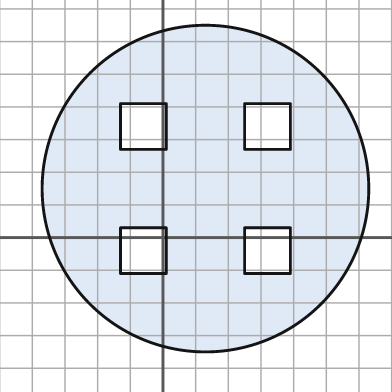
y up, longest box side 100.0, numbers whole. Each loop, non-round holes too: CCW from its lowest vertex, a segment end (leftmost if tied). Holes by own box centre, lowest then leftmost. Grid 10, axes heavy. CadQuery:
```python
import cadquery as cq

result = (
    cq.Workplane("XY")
    .moveTo(13.0, 15.0)
    .circle(50.0)
    .moveTo(-13.0, -11.0)
    .lineTo(1.0, -11.0)
    .lineTo(1.0, 3.0)
    .lineTo(-13.0, 3.0)
    .close()
    .moveTo(25.0, -11.0)
    .lineTo(39.0, -11.0)
    .lineTo(39.0, 3.0)
    .lineTo(25.0, 3.0)
    .close()
    .moveTo(-13.0, 27.0)
    .lineTo(1.0, 27.0)
    .lineTo(1.0, 41.0)
    .lineTo(-13.0, 41.0)
    .close()
    .moveTo(25.0, 27.0)
    .lineTo(39.0, 27.0)
    .lineTo(39.0, 41.0)
    .lineTo(25.0, 41.0)
    .close()
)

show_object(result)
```